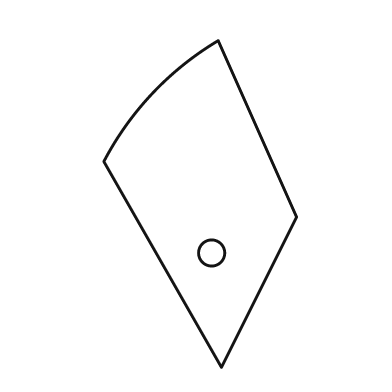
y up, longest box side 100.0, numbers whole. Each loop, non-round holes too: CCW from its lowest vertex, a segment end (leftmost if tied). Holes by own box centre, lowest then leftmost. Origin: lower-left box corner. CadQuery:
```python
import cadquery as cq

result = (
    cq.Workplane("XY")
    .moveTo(36.0, 0.0)
    .lineTo(59.0, 46.0)
    .lineTo(35.0, 100.0)
    .threePointArc((15.0, 84.0), (0.0, 63.0))
    .close()
    .moveTo(33.0, 35.0)
    .circle(4.0)
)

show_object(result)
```